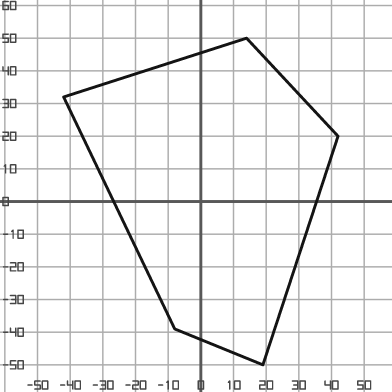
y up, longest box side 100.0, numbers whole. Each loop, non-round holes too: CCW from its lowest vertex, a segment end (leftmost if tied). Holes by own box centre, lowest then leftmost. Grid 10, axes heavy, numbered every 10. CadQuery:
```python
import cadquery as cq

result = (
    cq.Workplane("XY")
    .moveTo(19.0, -50.0)
    .lineTo(42.0, 20.0)
    .lineTo(14.0, 50.0)
    .lineTo(-42.0, 32.0)
    .lineTo(-8.0, -39.0)
    .close()
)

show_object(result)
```